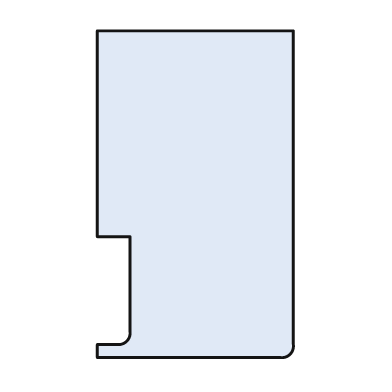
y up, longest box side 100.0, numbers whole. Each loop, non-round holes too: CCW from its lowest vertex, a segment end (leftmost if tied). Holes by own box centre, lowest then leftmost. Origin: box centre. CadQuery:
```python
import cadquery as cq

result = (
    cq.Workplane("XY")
    .moveTo(-30.0, -50.0)
    .lineTo(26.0, -50.0)
    .threePointArc((29.0, -49.0), (30.0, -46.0))
    .lineTo(30.0, 50.0)
    .lineTo(-30.0, 50.0)
    .lineTo(-30.0, -13.0)
    .lineTo(-20.0, -13.0)
    .lineTo(-20.0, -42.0)
    .threePointArc((-21.0, -45.0), (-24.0, -46.0))
    .lineTo(-30.0, -46.0)
    .close()
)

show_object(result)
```